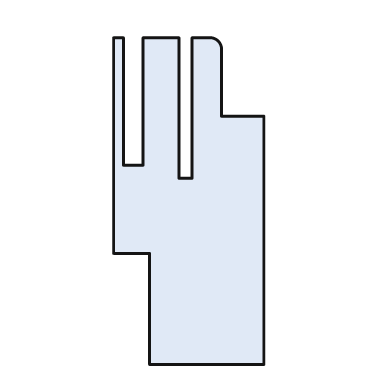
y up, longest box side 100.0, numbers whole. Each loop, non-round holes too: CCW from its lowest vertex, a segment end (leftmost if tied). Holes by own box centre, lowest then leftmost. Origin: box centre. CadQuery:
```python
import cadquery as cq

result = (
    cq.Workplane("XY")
    .moveTo(-12.0, -50.0)
    .lineTo(23.0, -50.0)
    .lineTo(23.0, 26.0)
    .lineTo(10.0, 26.0)
    .lineTo(10.0, 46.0)
    .threePointArc((9.0, 49.0), (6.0, 50.0))
    .lineTo(1.0, 50.0)
    .lineTo(1.0, 7.0)
    .lineTo(-3.0, 7.0)
    .lineTo(-3.0, 50.0)
    .lineTo(-14.0, 50.0)
    .lineTo(-14.0, 11.0)
    .lineTo(-20.0, 11.0)
    .lineTo(-20.0, 50.0)
    .lineTo(-23.0, 50.0)
    .lineTo(-23.0, -16.0)
    .lineTo(-12.0, -16.0)
    .close()
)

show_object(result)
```